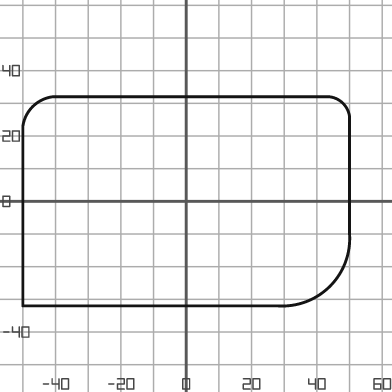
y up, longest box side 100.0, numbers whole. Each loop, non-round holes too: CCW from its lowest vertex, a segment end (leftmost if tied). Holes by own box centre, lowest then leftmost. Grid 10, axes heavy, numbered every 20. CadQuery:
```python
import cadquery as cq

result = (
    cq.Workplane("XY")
    .moveTo(-50.0, -32.0)
    .lineTo(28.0, -32.0)
    .threePointArc((44.0, -26.0), (50.0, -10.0))
    .lineTo(50.0, 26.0)
    .threePointArc((48.0, 30.0), (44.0, 32.0))
    .lineTo(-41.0, 32.0)
    .threePointArc((-47.0, 29.0), (-50.0, 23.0))
    .close()
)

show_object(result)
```